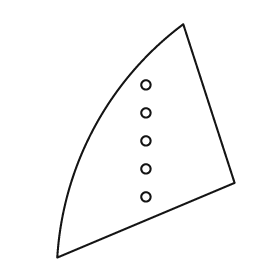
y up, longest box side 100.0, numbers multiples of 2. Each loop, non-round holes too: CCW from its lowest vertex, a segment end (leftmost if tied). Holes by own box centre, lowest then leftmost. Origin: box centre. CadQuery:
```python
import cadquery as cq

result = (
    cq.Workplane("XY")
    .moveTo(-38.0, -50.0)
    .lineTo(38.0, -18.0)
    .lineTo(16.0, 50.0)
    .threePointArc((-22.0, 6.0), (-38.0, -50.0))
    .close()
    .moveTo(0.0, -24.0)
    .circle(2.0)
    .moveTo(0.0, -12.0)
    .circle(2.0)
    .moveTo(0.0, 0.0)
    .circle(2.0)
    .moveTo(0.0, 12.0)
    .circle(2.0)
    .moveTo(0.0, 24.0)
    .circle(2.0)
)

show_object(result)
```